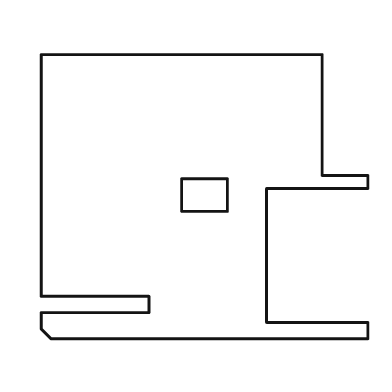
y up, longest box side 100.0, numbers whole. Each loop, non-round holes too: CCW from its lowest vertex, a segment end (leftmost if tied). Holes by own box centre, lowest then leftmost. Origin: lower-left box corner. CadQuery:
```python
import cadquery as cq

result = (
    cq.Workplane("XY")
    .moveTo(3.0, 0.0)
    .lineTo(100.0, 0.0)
    .lineTo(100.0, 5.0)
    .lineTo(69.0, 5.0)
    .lineTo(69.0, 46.0)
    .lineTo(100.0, 46.0)
    .lineTo(100.0, 50.0)
    .lineTo(86.0, 50.0)
    .lineTo(86.0, 87.0)
    .lineTo(0.0, 87.0)
    .lineTo(0.0, 13.0)
    .lineTo(33.0, 13.0)
    .lineTo(33.0, 8.0)
    .lineTo(0.0, 8.0)
    .lineTo(0.0, 3.0)
    .close()
    .moveTo(43.0, 39.0)
    .lineTo(57.0, 39.0)
    .lineTo(57.0, 49.0)
    .lineTo(43.0, 49.0)
    .close()
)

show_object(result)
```